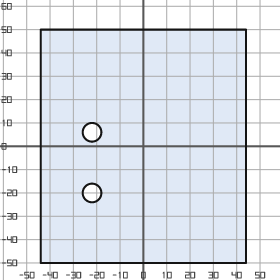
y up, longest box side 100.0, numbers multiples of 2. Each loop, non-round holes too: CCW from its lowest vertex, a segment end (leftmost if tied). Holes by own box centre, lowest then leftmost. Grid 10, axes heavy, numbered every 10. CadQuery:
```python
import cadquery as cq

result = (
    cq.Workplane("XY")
    .moveTo(-44.0, -50.0)
    .lineTo(44.0, -50.0)
    .lineTo(44.0, 50.0)
    .lineTo(-44.0, 50.0)
    .close()
    .moveTo(-22.0, -20.0)
    .circle(4.0)
    .moveTo(-22.0, 6.0)
    .circle(4.0)
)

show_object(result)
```